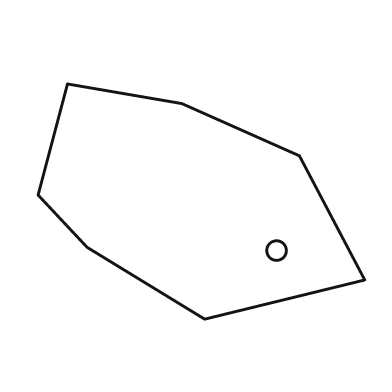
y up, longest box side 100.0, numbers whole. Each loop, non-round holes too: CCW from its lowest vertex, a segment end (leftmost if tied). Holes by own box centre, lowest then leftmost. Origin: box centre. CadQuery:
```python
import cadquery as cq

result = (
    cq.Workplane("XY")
    .moveTo(1.0, -36.0)
    .lineTo(50.0, -24.0)
    .lineTo(30.0, 14.0)
    .lineTo(-6.0, 30.0)
    .lineTo(-41.0, 36.0)
    .lineTo(-50.0, 2.0)
    .lineTo(-35.0, -14.0)
    .close()
    .moveTo(23.0, -15.0)
    .circle(3.0)
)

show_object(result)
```